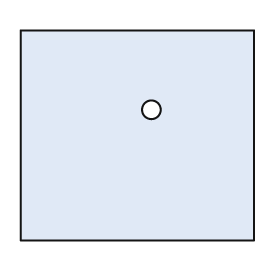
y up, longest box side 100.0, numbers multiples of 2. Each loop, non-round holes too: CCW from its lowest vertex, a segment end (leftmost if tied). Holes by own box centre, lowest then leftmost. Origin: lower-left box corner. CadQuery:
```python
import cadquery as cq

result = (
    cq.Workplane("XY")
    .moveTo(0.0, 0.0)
    .lineTo(100.0, 0.0)
    .lineTo(100.0, 90.0)
    .lineTo(0.0, 90.0)
    .close()
    .moveTo(56.0, 56.0)
    .circle(4.0)
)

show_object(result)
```